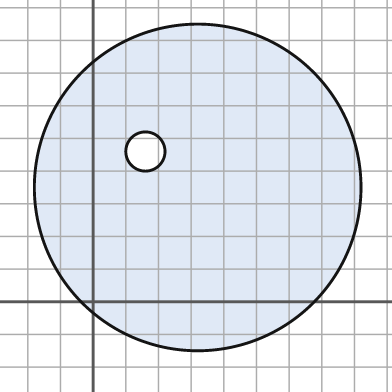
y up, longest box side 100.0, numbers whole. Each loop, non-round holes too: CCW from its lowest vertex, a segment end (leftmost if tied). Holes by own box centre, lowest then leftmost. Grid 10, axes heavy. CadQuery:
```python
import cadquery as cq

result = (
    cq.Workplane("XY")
    .moveTo(32.0, 35.0)
    .circle(50.0)
    .moveTo(16.0, 46.0)
    .circle(6.0)
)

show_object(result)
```